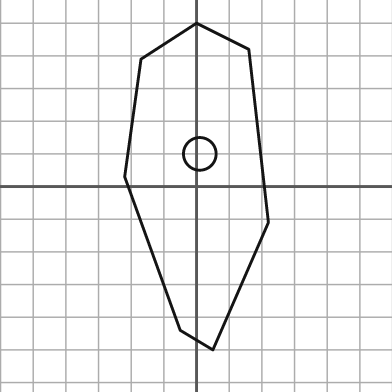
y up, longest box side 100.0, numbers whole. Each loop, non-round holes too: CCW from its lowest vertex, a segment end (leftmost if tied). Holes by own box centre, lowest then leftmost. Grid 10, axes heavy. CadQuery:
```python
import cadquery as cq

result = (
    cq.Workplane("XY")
    .moveTo(5.0, -50.0)
    .lineTo(22.0, -11.0)
    .lineTo(16.0, 42.0)
    .lineTo(0.0, 50.0)
    .lineTo(-17.0, 39.0)
    .lineTo(-22.0, 3.0)
    .lineTo(-5.0, -44.0)
    .close()
    .moveTo(1.0, 10.0)
    .circle(5.0)
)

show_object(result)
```